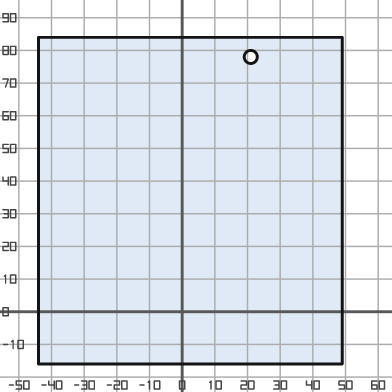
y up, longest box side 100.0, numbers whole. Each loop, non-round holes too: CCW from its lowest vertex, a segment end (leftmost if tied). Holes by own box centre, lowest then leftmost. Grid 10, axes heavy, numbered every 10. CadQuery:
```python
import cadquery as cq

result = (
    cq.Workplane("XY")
    .moveTo(-44.0, -16.0)
    .lineTo(49.0, -16.0)
    .lineTo(49.0, 84.0)
    .lineTo(-44.0, 84.0)
    .close()
    .moveTo(21.0, 78.0)
    .circle(2.0)
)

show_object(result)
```